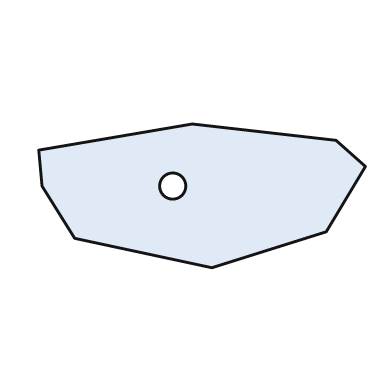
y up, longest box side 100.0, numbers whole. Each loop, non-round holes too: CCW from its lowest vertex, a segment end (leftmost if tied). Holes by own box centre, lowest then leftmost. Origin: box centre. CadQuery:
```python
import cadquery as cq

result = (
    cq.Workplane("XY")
    .moveTo(3.0, -22.0)
    .lineTo(38.0, -11.0)
    .lineTo(50.0, 9.0)
    .lineTo(41.0, 17.0)
    .lineTo(-3.0, 22.0)
    .lineTo(-50.0, 14.0)
    .lineTo(-49.0, 3.0)
    .lineTo(-39.0, -13.0)
    .close()
    .moveTo(-9.0, 3.0)
    .circle(4.0)
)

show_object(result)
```